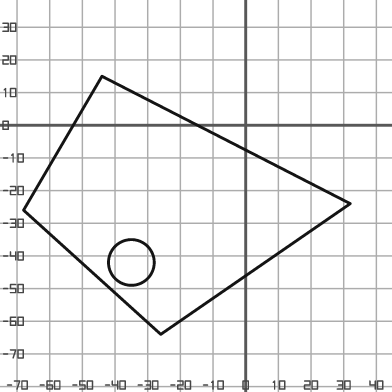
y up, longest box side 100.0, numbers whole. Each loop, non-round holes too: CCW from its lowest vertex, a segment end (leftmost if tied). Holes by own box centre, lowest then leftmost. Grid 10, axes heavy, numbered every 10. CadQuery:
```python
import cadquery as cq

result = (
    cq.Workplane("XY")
    .moveTo(-26.0, -64.0)
    .lineTo(32.0, -24.0)
    .lineTo(-44.0, 15.0)
    .lineTo(-68.0, -26.0)
    .close()
    .moveTo(-35.0, -42.0)
    .circle(7.0)
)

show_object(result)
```